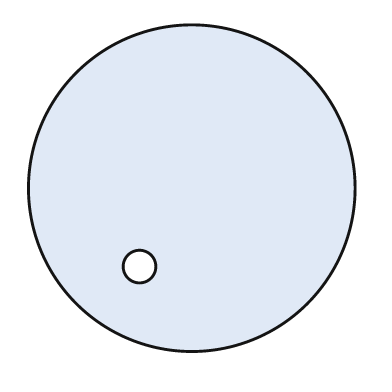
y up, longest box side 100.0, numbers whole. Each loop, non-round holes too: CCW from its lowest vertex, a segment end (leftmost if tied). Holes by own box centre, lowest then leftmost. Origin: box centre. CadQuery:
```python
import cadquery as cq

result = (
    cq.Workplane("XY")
    .moveTo(0.0, 0.0)
    .circle(50.0)
    .moveTo(-16.0, -24.0)
    .circle(5.0)
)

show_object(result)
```